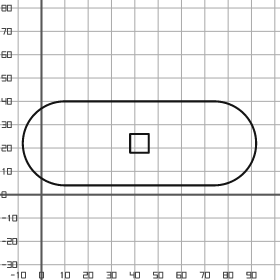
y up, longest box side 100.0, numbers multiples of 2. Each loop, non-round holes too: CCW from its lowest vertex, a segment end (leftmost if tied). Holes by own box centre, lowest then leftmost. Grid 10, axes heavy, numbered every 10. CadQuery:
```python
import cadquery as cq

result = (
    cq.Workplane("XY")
    .moveTo(10.0, 4.0)
    .lineTo(74.0, 4.0)
    .threePointArc((92.0, 22.0), (74.0, 40.0))
    .lineTo(10.0, 40.0)
    .threePointArc((-8.0, 22.0), (10.0, 4.0))
    .close()
    .moveTo(38.0, 18.0)
    .lineTo(46.0, 18.0)
    .lineTo(46.0, 26.0)
    .lineTo(38.0, 26.0)
    .close()
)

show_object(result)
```